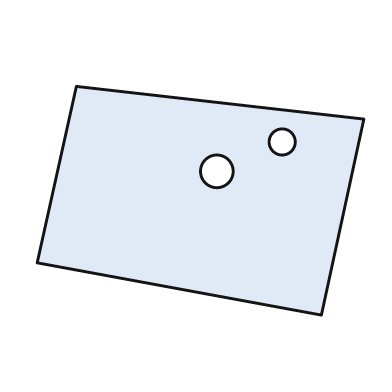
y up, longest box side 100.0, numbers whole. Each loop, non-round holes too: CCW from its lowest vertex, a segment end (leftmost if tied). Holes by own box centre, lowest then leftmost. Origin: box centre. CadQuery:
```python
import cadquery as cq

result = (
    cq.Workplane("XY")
    .moveTo(37.0, -35.0)
    .lineTo(50.0, 25.0)
    .lineTo(-38.0, 35.0)
    .lineTo(-50.0, -19.0)
    .close()
    .moveTo(5.0, 9.0)
    .circle(5.0)
    .moveTo(25.0, 18.0)
    .circle(4.0)
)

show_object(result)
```